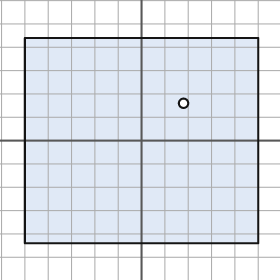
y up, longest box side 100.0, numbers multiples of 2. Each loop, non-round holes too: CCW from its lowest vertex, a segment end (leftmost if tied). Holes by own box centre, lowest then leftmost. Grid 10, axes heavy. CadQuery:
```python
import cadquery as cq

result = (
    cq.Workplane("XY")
    .moveTo(-50.0, -44.0)
    .lineTo(50.0, -44.0)
    .lineTo(50.0, 44.0)
    .lineTo(-50.0, 44.0)
    .close()
    .moveTo(18.0, 16.0)
    .circle(2.0)
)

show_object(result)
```